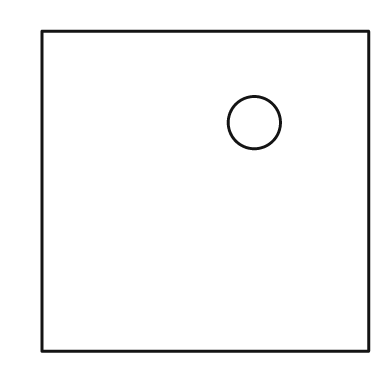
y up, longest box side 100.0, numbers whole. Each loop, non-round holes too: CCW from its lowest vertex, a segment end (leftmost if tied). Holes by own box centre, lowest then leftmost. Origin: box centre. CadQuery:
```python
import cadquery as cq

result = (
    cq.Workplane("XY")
    .moveTo(-50.0, -49.0)
    .lineTo(50.0, -49.0)
    .lineTo(50.0, 49.0)
    .lineTo(-50.0, 49.0)
    .close()
    .moveTo(15.0, 21.0)
    .circle(8.0)
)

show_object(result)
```